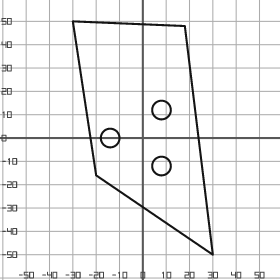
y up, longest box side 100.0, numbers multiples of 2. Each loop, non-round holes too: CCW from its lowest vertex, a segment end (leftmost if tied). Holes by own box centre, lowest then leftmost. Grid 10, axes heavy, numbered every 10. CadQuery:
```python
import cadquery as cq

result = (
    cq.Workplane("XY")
    .moveTo(30.0, -50.0)
    .lineTo(18.0, 48.0)
    .lineTo(-30.0, 50.0)
    .lineTo(-20.0, -16.0)
    .close()
    .moveTo(8.0, -12.0)
    .circle(4.0)
    .moveTo(-14.0, 0.0)
    .circle(4.0)
    .moveTo(8.0, 12.0)
    .circle(4.0)
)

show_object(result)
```